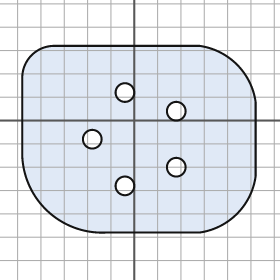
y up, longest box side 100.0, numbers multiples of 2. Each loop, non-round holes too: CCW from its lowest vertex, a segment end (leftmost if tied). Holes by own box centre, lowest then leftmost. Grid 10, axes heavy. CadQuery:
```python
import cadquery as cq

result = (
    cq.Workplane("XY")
    .moveTo(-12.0, -48.0)
    .lineTo(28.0, -48.0)
    .threePointArc((44.0, -40.0), (52.0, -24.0))
    .lineTo(52.0, 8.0)
    .threePointArc((44.0, 24.0), (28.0, 32.0))
    .lineTo(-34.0, 32.0)
    .threePointArc((-44.0, 28.0), (-48.0, 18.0))
    .lineTo(-48.0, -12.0)
    .threePointArc((-38.0, -38.0), (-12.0, -48.0))
    .close()
    .moveTo(-4.0, -28.0)
    .circle(4.0)
    .moveTo(18.0, -20.0)
    .circle(4.0)
    .moveTo(-18.0, -8.0)
    .circle(4.0)
    .moveTo(18.0, 4.0)
    .circle(4.0)
    .moveTo(-4.0, 12.0)
    .circle(4.0)
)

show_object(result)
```